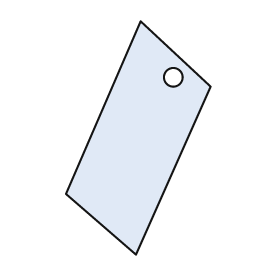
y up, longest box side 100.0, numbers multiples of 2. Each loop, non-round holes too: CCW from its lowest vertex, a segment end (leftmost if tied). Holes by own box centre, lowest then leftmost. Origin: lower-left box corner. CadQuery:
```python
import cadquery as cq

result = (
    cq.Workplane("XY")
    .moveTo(30.0, 0.0)
    .lineTo(62.0, 72.0)
    .lineTo(32.0, 100.0)
    .lineTo(0.0, 26.0)
    .close()
    .moveTo(46.0, 76.0)
    .circle(4.0)
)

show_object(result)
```